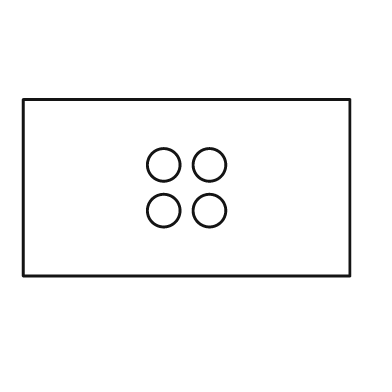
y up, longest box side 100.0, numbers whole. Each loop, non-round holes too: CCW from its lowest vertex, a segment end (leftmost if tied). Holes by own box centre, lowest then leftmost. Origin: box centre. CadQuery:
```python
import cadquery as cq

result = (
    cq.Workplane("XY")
    .moveTo(-50.0, -27.0)
    .lineTo(50.0, -27.0)
    .lineTo(50.0, 27.0)
    .lineTo(-50.0, 27.0)
    .close()
    .moveTo(-7.0, -7.0)
    .circle(5.0)
    .moveTo(7.0, -7.0)
    .circle(5.0)
    .moveTo(-7.0, 7.0)
    .circle(5.0)
    .moveTo(7.0, 7.0)
    .circle(5.0)
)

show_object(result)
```